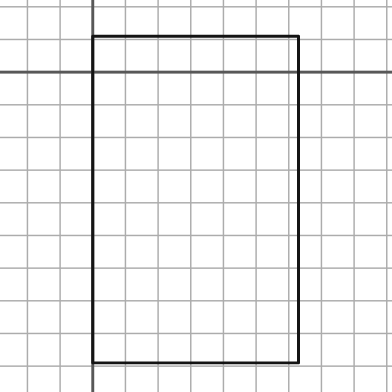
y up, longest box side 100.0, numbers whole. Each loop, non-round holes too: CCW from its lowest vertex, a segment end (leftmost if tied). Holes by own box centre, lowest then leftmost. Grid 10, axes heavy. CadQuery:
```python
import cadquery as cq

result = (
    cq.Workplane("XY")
    .moveTo(0.0, -89.0)
    .lineTo(63.0, -89.0)
    .lineTo(63.0, 11.0)
    .lineTo(0.0, 11.0)
    .close()
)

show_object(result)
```